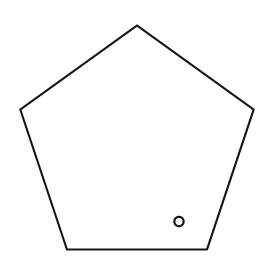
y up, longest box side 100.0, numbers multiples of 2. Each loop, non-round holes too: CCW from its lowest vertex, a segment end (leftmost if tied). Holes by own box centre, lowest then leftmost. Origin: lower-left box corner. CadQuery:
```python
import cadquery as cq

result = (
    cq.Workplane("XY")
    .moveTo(20.0, 0.0)
    .lineTo(80.0, 0.0)
    .lineTo(100.0, 60.0)
    .lineTo(50.0, 96.0)
    .lineTo(0.0, 60.0)
    .close()
    .moveTo(68.0, 12.0)
    .circle(2.0)
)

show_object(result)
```